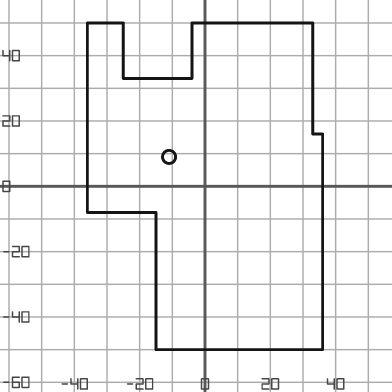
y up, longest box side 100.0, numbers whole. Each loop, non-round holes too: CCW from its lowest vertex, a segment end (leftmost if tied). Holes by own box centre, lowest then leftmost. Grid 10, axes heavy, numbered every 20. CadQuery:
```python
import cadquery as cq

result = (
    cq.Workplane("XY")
    .moveTo(-15.0, -50.0)
    .lineTo(36.0, -50.0)
    .lineTo(36.0, 16.0)
    .lineTo(33.0, 16.0)
    .lineTo(33.0, 50.0)
    .lineTo(-4.0, 50.0)
    .lineTo(-4.0, 33.0)
    .lineTo(-25.0, 33.0)
    .lineTo(-25.0, 50.0)
    .lineTo(-36.0, 50.0)
    .lineTo(-36.0, -8.0)
    .lineTo(-15.0, -8.0)
    .close()
    .moveTo(-11.0, 9.0)
    .circle(2.0)
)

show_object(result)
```